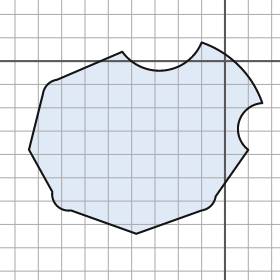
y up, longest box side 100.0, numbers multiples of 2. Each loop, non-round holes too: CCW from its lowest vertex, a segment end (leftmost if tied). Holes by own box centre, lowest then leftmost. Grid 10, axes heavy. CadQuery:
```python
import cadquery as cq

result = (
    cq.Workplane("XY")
    .moveTo(-38.0, -74.0)
    .lineTo(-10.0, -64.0)
    .threePointArc((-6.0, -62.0), (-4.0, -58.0))
    .lineTo(10.0, -38.0)
    .threePointArc((6.0, -26.0), (16.0, -18.0))
    .threePointArc((6.0, -2.0), (-10.0, 8.0))
    .threePointArc((-26.0, -4.0), (-44.0, 4.0))
    .lineTo(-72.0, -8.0)
    .threePointArc((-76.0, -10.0), (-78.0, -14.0))
    .lineTo(-84.0, -38.0)
    .lineTo(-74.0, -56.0)
    .threePointArc((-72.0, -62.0), (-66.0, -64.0))
    .close()
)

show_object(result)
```